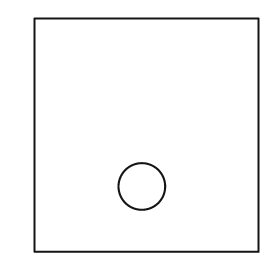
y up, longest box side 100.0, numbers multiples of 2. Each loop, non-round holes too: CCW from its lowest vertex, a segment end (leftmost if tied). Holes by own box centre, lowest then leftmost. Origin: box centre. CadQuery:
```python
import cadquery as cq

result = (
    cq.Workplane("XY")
    .moveTo(-48.0, -50.0)
    .lineTo(48.0, -50.0)
    .lineTo(48.0, 50.0)
    .lineTo(-48.0, 50.0)
    .close()
    .moveTo(-2.0, -22.0)
    .circle(10.0)
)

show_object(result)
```